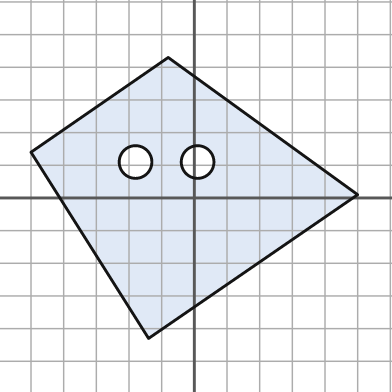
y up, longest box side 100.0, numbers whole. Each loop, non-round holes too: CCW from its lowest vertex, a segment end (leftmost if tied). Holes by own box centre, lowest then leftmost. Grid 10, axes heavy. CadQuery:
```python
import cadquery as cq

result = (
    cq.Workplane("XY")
    .moveTo(-14.0, -43.0)
    .lineTo(50.0, 1.0)
    .lineTo(-8.0, 43.0)
    .lineTo(-50.0, 14.0)
    .close()
    .moveTo(-18.0, 11.0)
    .circle(5.0)
    .moveTo(1.0, 11.0)
    .circle(5.0)
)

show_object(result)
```